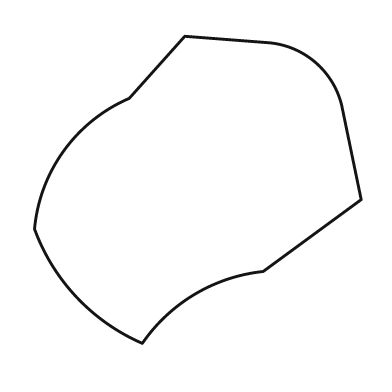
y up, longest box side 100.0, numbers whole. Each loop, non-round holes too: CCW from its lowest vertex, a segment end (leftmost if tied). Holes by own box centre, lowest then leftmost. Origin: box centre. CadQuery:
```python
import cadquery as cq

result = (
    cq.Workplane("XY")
    .moveTo(-17.0, -47.0)
    .threePointArc((-1.0, -32.0), (20.0, -25.0))
    .lineTo(50.0, -3.0)
    .lineTo(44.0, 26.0)
    .threePointArc((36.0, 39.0), (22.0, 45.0))
    .lineTo(-4.0, 47.0)
    .lineTo(-21.0, 28.0)
    .threePointArc((-41.0, 12.0), (-50.0, -12.0))
    .threePointArc((-37.0, -33.0), (-17.0, -47.0))
    .close()
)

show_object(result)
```